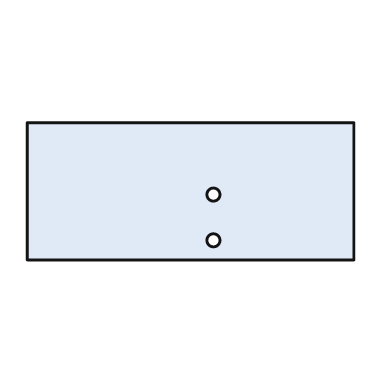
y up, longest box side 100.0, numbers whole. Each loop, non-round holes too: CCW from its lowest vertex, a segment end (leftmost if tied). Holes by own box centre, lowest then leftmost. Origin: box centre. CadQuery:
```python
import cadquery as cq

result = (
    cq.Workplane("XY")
    .moveTo(-50.0, -21.0)
    .lineTo(50.0, -21.0)
    .lineTo(50.0, 21.0)
    .lineTo(-50.0, 21.0)
    .close()
    .moveTo(7.0, -15.0)
    .circle(2.0)
    .moveTo(7.0, -1.0)
    .circle(2.0)
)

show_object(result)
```